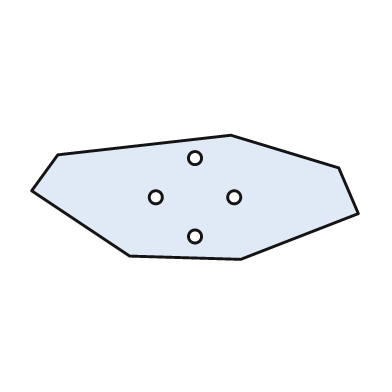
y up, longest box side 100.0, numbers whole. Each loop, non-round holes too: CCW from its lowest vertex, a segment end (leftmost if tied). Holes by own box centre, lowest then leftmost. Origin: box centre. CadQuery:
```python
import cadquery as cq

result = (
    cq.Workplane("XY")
    .moveTo(14.0, -19.0)
    .lineTo(50.0, -5.0)
    .lineTo(44.0, 9.0)
    .lineTo(11.0, 19.0)
    .lineTo(-42.0, 13.0)
    .lineTo(-50.0, 2.0)
    .lineTo(-20.0, -18.0)
    .close()
    .moveTo(0.0, -12.0)
    .circle(2.0)
    .moveTo(-12.0, 0.0)
    .circle(2.0)
    .moveTo(12.0, 0.0)
    .circle(2.0)
    .moveTo(0.0, 12.0)
    .circle(2.0)
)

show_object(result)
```